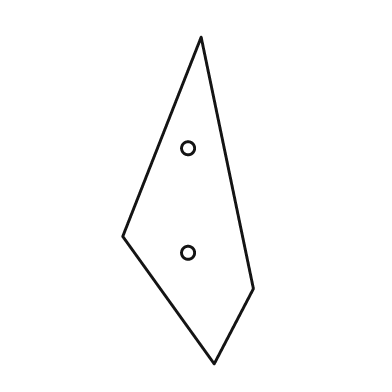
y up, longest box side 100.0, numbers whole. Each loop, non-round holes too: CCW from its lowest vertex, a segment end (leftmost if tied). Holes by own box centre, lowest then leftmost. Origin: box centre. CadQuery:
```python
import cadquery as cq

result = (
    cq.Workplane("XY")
    .moveTo(8.0, -50.0)
    .lineTo(20.0, -27.0)
    .lineTo(4.0, 50.0)
    .lineTo(-20.0, -11.0)
    .close()
    .moveTo(0.0, -16.0)
    .circle(2.0)
    .moveTo(0.0, 16.0)
    .circle(2.0)
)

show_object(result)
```